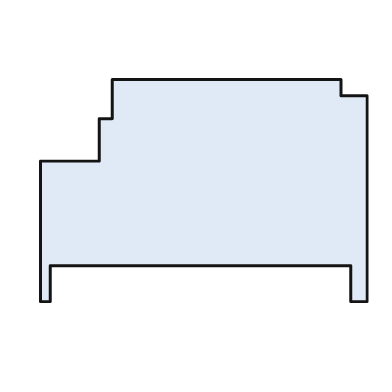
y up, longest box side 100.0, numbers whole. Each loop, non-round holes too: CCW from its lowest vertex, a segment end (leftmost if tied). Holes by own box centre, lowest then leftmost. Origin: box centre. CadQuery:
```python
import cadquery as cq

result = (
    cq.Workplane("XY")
    .moveTo(-50.0, -34.0)
    .lineTo(-47.0, -34.0)
    .lineTo(-47.0, -23.0)
    .lineTo(45.0, -23.0)
    .lineTo(45.0, -34.0)
    .lineTo(50.0, -34.0)
    .lineTo(50.0, 29.0)
    .lineTo(42.0, 29.0)
    .lineTo(42.0, 34.0)
    .lineTo(-28.0, 34.0)
    .lineTo(-28.0, 22.0)
    .lineTo(-32.0, 22.0)
    .lineTo(-32.0, 9.0)
    .lineTo(-50.0, 9.0)
    .close()
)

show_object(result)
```